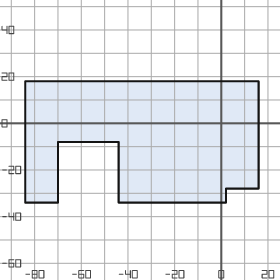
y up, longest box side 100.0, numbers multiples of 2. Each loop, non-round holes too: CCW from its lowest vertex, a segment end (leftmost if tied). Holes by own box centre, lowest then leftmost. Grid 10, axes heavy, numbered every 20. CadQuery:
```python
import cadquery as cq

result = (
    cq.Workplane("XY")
    .moveTo(-84.0, -34.0)
    .lineTo(-70.0, -34.0)
    .lineTo(-70.0, -8.0)
    .lineTo(-44.0, -8.0)
    .lineTo(-44.0, -34.0)
    .lineTo(2.0, -34.0)
    .lineTo(2.0, -28.0)
    .lineTo(16.0, -28.0)
    .lineTo(16.0, 18.0)
    .lineTo(-84.0, 18.0)
    .close()
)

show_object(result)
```